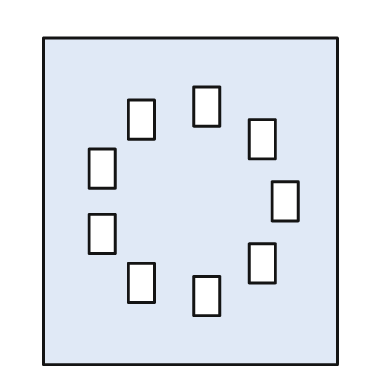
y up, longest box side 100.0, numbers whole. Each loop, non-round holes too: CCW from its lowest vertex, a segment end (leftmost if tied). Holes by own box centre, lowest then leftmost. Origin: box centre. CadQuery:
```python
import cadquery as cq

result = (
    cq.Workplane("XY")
    .moveTo(-45.0, -50.0)
    .lineTo(45.0, -50.0)
    .lineTo(45.0, 50.0)
    .lineTo(-45.0, 50.0)
    .close()
    .moveTo(1.0, -35.0)
    .lineTo(9.0, -35.0)
    .lineTo(9.0, -23.0)
    .lineTo(1.0, -23.0)
    .close()
    .moveTo(-19.0, -31.0)
    .lineTo(-11.0, -31.0)
    .lineTo(-11.0, -19.0)
    .lineTo(-19.0, -19.0)
    .close()
    .moveTo(18.0, -25.0)
    .lineTo(26.0, -25.0)
    .lineTo(26.0, -13.0)
    .lineTo(18.0, -13.0)
    .close()
    .moveTo(-31.0, -16.0)
    .lineTo(-23.0, -16.0)
    .lineTo(-23.0, -4.0)
    .lineTo(-31.0, -4.0)
    .close()
    .moveTo(25.0, -6.0)
    .lineTo(33.0, -6.0)
    .lineTo(33.0, 6.0)
    .lineTo(25.0, 6.0)
    .close()
    .moveTo(-31.0, 4.0)
    .lineTo(-23.0, 4.0)
    .lineTo(-23.0, 16.0)
    .lineTo(-31.0, 16.0)
    .close()
    .moveTo(18.0, 13.0)
    .lineTo(26.0, 13.0)
    .lineTo(26.0, 25.0)
    .lineTo(18.0, 25.0)
    .close()
    .moveTo(-19.0, 19.0)
    .lineTo(-11.0, 19.0)
    .lineTo(-11.0, 31.0)
    .lineTo(-19.0, 31.0)
    .close()
    .moveTo(1.0, 23.0)
    .lineTo(9.0, 23.0)
    .lineTo(9.0, 35.0)
    .lineTo(1.0, 35.0)
    .close()
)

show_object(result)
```